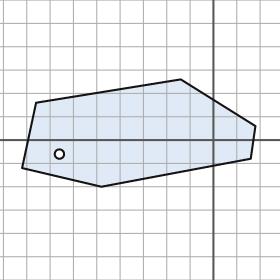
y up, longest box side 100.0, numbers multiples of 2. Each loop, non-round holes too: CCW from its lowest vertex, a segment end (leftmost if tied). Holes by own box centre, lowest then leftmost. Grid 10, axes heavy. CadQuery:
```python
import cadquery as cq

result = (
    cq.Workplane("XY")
    .moveTo(-48.0, -20.0)
    .lineTo(16.0, -8.0)
    .lineTo(18.0, 6.0)
    .lineTo(-14.0, 26.0)
    .lineTo(-76.0, 16.0)
    .lineTo(-82.0, -12.0)
    .close()
    .moveTo(-66.0, -6.0)
    .circle(2.0)
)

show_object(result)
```